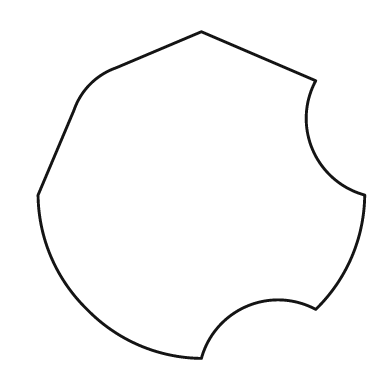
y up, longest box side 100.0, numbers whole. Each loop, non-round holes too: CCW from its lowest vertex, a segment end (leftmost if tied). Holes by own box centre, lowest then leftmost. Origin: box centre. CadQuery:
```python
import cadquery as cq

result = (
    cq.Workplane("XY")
    .moveTo(0.0, -50.0)
    .threePointArc((14.0, -34.0), (35.0, -35.0))
    .threePointArc((46.0, -19.0), (50.0, 0.0))
    .threePointArc((34.0, 14.0), (35.0, 35.0))
    .lineTo(0.0, 50.0)
    .lineTo(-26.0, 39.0)
    .threePointArc((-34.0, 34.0), (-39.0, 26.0))
    .lineTo(-50.0, 0.0)
    .threePointArc((-46.0, -19.0), (-35.0, -35.0))
    .threePointArc((-19.0, -46.0), (0.0, -50.0))
    .close()
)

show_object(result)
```